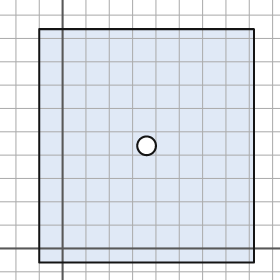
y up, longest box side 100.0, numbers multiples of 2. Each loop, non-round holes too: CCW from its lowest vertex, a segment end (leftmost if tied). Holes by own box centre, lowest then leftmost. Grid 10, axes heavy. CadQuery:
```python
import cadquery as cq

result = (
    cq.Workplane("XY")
    .moveTo(-10.0, -6.0)
    .lineTo(82.0, -6.0)
    .lineTo(82.0, 94.0)
    .lineTo(-10.0, 94.0)
    .close()
    .moveTo(36.0, 44.0)
    .circle(4.0)
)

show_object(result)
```